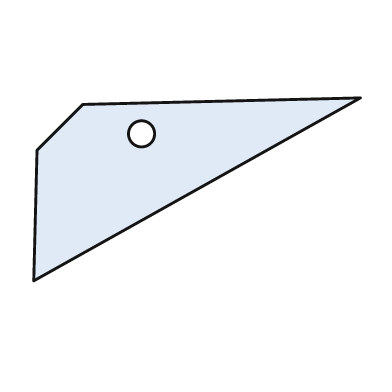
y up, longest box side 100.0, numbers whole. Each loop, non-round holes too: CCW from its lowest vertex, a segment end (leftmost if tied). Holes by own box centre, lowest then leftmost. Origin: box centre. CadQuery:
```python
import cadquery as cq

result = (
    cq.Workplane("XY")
    .moveTo(-50.0, -28.0)
    .lineTo(50.0, 28.0)
    .lineTo(-35.0, 26.0)
    .lineTo(-49.0, 12.0)
    .close()
    .moveTo(-17.0, 17.0)
    .circle(4.0)
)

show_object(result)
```